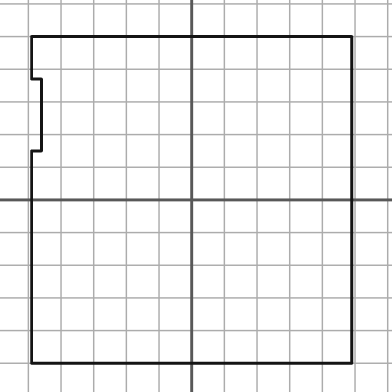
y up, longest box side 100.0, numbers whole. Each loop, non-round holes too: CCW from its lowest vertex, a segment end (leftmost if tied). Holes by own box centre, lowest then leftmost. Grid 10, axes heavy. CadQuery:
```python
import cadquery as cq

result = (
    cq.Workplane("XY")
    .moveTo(-49.0, -50.0)
    .lineTo(49.0, -50.0)
    .lineTo(49.0, 50.0)
    .lineTo(-49.0, 50.0)
    .lineTo(-49.0, 37.0)
    .lineTo(-46.0, 37.0)
    .lineTo(-46.0, 15.0)
    .lineTo(-49.0, 15.0)
    .close()
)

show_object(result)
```